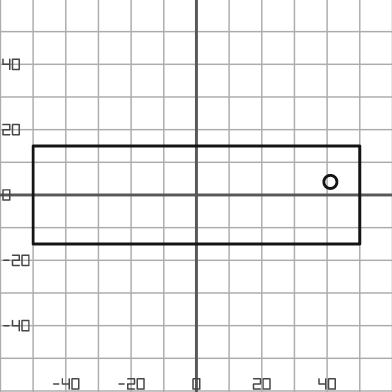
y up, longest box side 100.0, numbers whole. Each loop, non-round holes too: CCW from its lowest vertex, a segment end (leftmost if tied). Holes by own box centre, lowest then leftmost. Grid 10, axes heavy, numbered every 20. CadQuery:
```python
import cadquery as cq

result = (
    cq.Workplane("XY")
    .moveTo(-50.0, -15.0)
    .lineTo(50.0, -15.0)
    .lineTo(50.0, 15.0)
    .lineTo(-50.0, 15.0)
    .close()
    .moveTo(41.0, 4.0)
    .circle(2.0)
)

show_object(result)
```